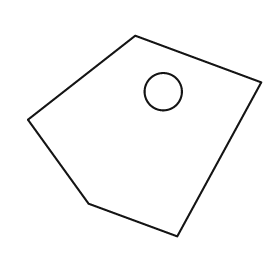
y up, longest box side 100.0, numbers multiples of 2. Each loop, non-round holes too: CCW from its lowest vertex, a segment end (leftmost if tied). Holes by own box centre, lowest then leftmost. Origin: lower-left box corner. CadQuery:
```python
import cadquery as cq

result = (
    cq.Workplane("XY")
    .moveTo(64.0, 0.0)
    .lineTo(100.0, 66.0)
    .lineTo(46.0, 86.0)
    .lineTo(0.0, 50.0)
    .lineTo(26.0, 14.0)
    .close()
    .moveTo(58.0, 62.0)
    .circle(8.0)
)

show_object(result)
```